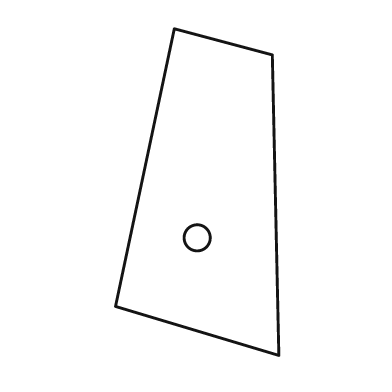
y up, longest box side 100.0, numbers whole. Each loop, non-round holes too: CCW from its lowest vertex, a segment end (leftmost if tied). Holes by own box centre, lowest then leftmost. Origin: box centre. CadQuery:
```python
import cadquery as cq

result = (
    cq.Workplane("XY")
    .moveTo(25.0, -50.0)
    .lineTo(23.0, 42.0)
    .lineTo(-7.0, 50.0)
    .lineTo(-25.0, -35.0)
    .close()
    .moveTo(0.0, -14.0)
    .circle(4.0)
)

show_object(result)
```